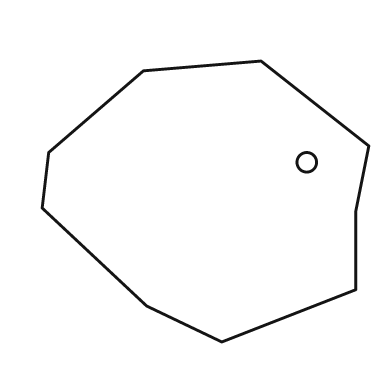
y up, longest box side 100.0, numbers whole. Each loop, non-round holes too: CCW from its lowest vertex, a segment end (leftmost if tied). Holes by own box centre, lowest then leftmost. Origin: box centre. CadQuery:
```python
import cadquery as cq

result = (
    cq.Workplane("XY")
    .moveTo(5.0, -43.0)
    .lineTo(46.0, -27.0)
    .lineTo(46.0, -3.0)
    .lineTo(50.0, 17.0)
    .lineTo(17.0, 43.0)
    .lineTo(-19.0, 40.0)
    .lineTo(-48.0, 15.0)
    .lineTo(-50.0, -2.0)
    .lineTo(-18.0, -32.0)
    .close()
    .moveTo(31.0, 12.0)
    .circle(3.0)
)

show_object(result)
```